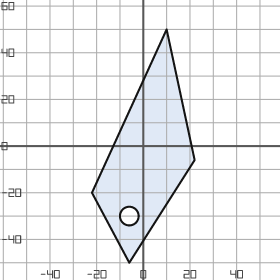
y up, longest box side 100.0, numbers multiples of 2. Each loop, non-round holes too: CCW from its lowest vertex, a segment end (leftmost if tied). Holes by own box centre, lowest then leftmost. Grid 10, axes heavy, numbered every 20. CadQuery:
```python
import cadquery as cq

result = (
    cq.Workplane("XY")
    .moveTo(-6.0, -50.0)
    .lineTo(22.0, -6.0)
    .lineTo(10.0, 50.0)
    .lineTo(-22.0, -20.0)
    .close()
    .moveTo(-6.0, -30.0)
    .circle(4.0)
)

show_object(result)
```